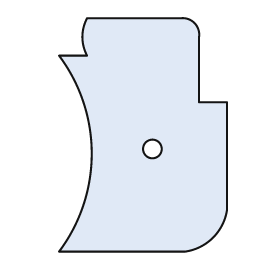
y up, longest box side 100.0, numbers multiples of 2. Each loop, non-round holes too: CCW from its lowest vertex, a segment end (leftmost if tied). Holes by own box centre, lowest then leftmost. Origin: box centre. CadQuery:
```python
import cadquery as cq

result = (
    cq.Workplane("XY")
    .moveTo(-36.0, -50.0)
    .lineTo(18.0, -50.0)
    .threePointArc((30.0, -44.0), (36.0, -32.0))
    .lineTo(36.0, 14.0)
    .lineTo(24.0, 14.0)
    .lineTo(24.0, 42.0)
    .threePointArc((22.0, 48.0), (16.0, 50.0))
    .lineTo(-24.0, 50.0)
    .threePointArc((-26.0, 42.0), (-24.0, 34.0))
    .lineTo(-36.0, 34.0)
    .threePointArc((-22.0, -8.0), (-36.0, -50.0))
    .close()
    .moveTo(4.0, -6.0)
    .circle(4.0)
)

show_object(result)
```